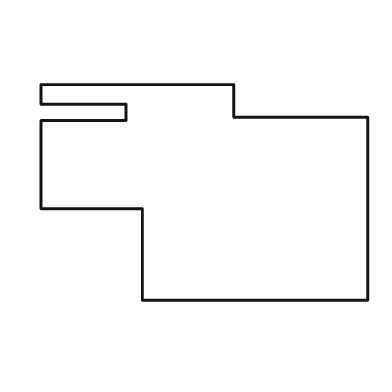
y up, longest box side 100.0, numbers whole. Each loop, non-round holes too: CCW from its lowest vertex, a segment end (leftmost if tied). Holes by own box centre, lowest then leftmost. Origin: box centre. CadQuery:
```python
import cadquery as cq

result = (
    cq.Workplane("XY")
    .moveTo(-19.0, -33.0)
    .lineTo(50.0, -33.0)
    .lineTo(50.0, 23.0)
    .lineTo(9.0, 23.0)
    .lineTo(9.0, 33.0)
    .lineTo(-50.0, 33.0)
    .lineTo(-50.0, 27.0)
    .lineTo(-24.0, 27.0)
    .lineTo(-24.0, 22.0)
    .lineTo(-50.0, 22.0)
    .lineTo(-50.0, -5.0)
    .lineTo(-19.0, -5.0)
    .close()
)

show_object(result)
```